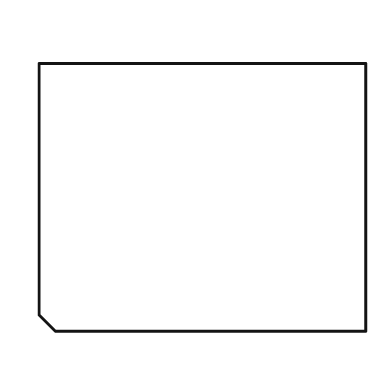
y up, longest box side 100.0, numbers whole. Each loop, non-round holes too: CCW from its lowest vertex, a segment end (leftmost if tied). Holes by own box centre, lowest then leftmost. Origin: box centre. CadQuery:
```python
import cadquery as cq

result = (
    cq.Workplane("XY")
    .moveTo(-45.0, -41.0)
    .lineTo(50.0, -41.0)
    .lineTo(50.0, 41.0)
    .lineTo(-50.0, 41.0)
    .lineTo(-50.0, -36.0)
    .close()
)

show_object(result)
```